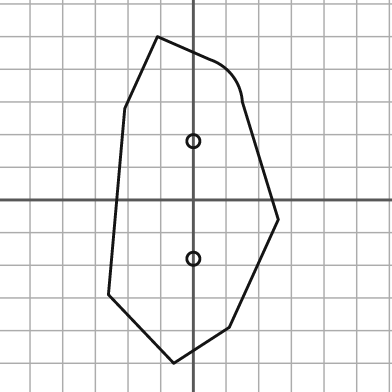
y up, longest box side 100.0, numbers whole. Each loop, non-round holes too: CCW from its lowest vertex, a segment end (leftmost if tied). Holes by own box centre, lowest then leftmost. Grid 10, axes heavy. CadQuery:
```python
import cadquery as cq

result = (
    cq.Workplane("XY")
    .moveTo(-6.0, -50.0)
    .lineTo(11.0, -39.0)
    .lineTo(26.0, -6.0)
    .lineTo(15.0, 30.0)
    .threePointArc((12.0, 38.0), (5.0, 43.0))
    .lineTo(-11.0, 50.0)
    .lineTo(-21.0, 28.0)
    .lineTo(-26.0, -29.0)
    .close()
    .moveTo(0.0, -18.0)
    .circle(2.0)
    .moveTo(0.0, 18.0)
    .circle(2.0)
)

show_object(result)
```